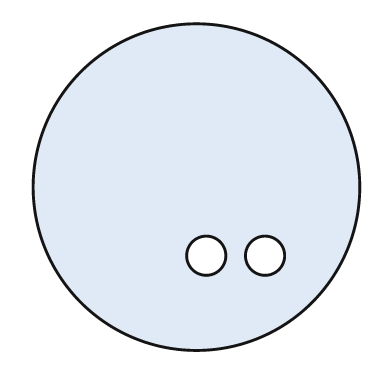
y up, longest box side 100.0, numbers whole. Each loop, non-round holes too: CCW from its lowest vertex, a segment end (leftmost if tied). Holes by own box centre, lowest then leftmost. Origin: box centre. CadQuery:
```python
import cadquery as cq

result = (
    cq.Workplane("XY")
    .moveTo(0.0, 0.0)
    .circle(50.0)
    .moveTo(3.0, -21.0)
    .circle(6.0)
    .moveTo(21.0, -21.0)
    .circle(6.0)
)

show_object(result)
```